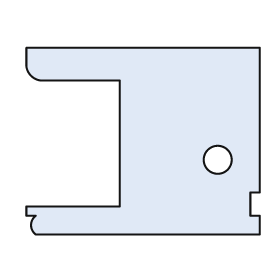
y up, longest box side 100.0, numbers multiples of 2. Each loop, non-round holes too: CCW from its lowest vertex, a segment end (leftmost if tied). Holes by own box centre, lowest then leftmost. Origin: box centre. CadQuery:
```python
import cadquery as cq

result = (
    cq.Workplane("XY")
    .moveTo(-46.0, -40.0)
    .lineTo(50.0, -40.0)
    .lineTo(50.0, -32.0)
    .lineTo(46.0, -32.0)
    .lineTo(46.0, -22.0)
    .lineTo(50.0, -22.0)
    .lineTo(50.0, 40.0)
    .lineTo(-50.0, 40.0)
    .lineTo(-50.0, 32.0)
    .threePointArc((-48.0, 28.0), (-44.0, 26.0))
    .lineTo(-10.0, 26.0)
    .lineTo(-10.0, -28.0)
    .lineTo(-50.0, -28.0)
    .lineTo(-50.0, -32.0)
    .lineTo(-46.0, -32.0)
    .threePointArc((-48.0, -36.0), (-46.0, -40.0))
    .close()
    .moveTo(32.0, -8.0)
    .circle(6.0)
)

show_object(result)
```